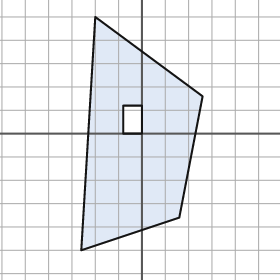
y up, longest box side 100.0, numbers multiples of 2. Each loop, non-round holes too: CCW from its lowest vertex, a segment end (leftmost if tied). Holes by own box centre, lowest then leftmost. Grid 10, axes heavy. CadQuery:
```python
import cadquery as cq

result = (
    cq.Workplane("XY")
    .moveTo(-26.0, -50.0)
    .lineTo(16.0, -36.0)
    .lineTo(26.0, 16.0)
    .lineTo(-20.0, 50.0)
    .close()
    .moveTo(-8.0, 0.0)
    .lineTo(0.0, 0.0)
    .lineTo(0.0, 12.0)
    .lineTo(-8.0, 12.0)
    .close()
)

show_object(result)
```